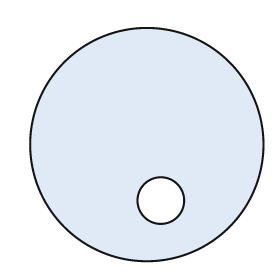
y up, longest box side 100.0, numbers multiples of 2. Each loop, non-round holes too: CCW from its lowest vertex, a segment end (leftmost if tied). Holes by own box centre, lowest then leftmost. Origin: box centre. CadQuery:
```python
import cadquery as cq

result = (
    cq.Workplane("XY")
    .moveTo(0.0, 0.0)
    .circle(50.0)
    .moveTo(6.0, -24.0)
    .circle(10.0)
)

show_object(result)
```